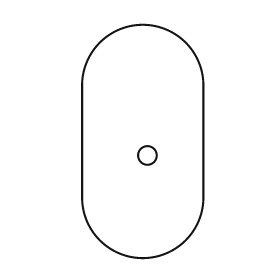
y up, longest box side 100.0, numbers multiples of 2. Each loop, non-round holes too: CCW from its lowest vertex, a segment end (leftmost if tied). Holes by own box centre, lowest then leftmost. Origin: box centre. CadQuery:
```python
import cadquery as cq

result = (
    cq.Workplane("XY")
    .moveTo(-26.0, -24.0)
    .threePointArc((0.0, -50.0), (26.0, -24.0))
    .lineTo(26.0, 24.0)
    .threePointArc((0.0, 50.0), (-26.0, 24.0))
    .close()
    .moveTo(2.0, -6.0)
    .circle(4.0)
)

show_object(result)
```